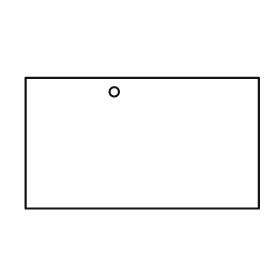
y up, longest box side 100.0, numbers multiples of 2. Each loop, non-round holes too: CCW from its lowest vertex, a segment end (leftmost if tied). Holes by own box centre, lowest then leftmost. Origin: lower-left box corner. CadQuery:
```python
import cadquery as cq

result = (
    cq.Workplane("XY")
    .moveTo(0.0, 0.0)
    .lineTo(100.0, 0.0)
    .lineTo(100.0, 56.0)
    .lineTo(0.0, 56.0)
    .close()
    .moveTo(38.0, 50.0)
    .circle(2.0)
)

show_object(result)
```